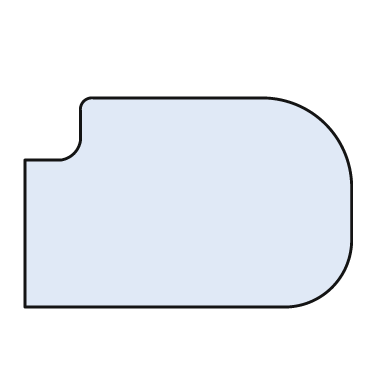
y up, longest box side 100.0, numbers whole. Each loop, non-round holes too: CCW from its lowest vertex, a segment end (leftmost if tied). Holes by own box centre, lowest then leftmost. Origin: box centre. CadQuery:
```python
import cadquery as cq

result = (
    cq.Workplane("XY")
    .moveTo(-50.0, -32.0)
    .lineTo(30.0, -32.0)
    .threePointArc((44.0, -26.0), (50.0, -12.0))
    .lineTo(50.0, 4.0)
    .threePointArc((42.0, 24.0), (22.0, 32.0))
    .lineTo(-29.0, 32.0)
    .threePointArc((-32.0, 31.0), (-33.0, 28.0))
    .lineTo(-33.0, 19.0)
    .threePointArc((-35.0, 15.0), (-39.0, 13.0))
    .lineTo(-50.0, 13.0)
    .close()
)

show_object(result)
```